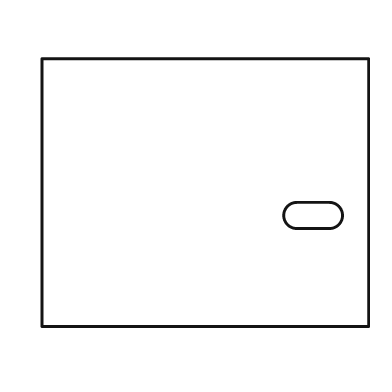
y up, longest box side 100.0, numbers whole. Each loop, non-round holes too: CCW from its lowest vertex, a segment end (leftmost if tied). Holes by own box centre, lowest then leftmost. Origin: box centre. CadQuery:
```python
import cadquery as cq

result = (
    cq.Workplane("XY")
    .moveTo(-50.0, -41.0)
    .lineTo(50.0, -41.0)
    .lineTo(50.0, 41.0)
    .lineTo(-50.0, 41.0)
    .close()
    .moveTo(28.0, -11.0)
    .lineTo(38.0, -11.0)
    .threePointArc((42.0, -7.0), (38.0, -3.0))
    .lineTo(28.0, -3.0)
    .threePointArc((24.0, -7.0), (28.0, -11.0))
    .close()
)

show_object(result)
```